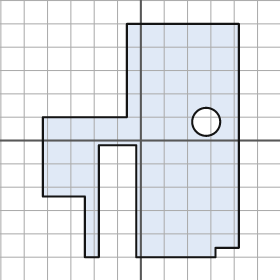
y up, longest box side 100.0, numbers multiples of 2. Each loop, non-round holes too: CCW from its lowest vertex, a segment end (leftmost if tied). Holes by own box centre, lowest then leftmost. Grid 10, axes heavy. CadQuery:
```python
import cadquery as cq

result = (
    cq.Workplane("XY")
    .moveTo(-24.0, -50.0)
    .lineTo(-18.0, -50.0)
    .lineTo(-18.0, -2.0)
    .lineTo(-2.0, -2.0)
    .lineTo(-2.0, -50.0)
    .lineTo(32.0, -50.0)
    .lineTo(32.0, -46.0)
    .lineTo(42.0, -46.0)
    .lineTo(42.0, 50.0)
    .lineTo(-6.0, 50.0)
    .lineTo(-6.0, 10.0)
    .lineTo(-42.0, 10.0)
    .lineTo(-42.0, -24.0)
    .lineTo(-24.0, -24.0)
    .close()
    .moveTo(28.0, 8.0)
    .circle(6.0)
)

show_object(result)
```